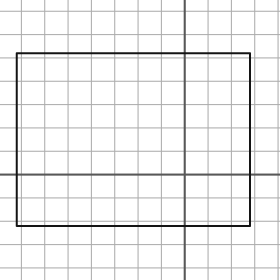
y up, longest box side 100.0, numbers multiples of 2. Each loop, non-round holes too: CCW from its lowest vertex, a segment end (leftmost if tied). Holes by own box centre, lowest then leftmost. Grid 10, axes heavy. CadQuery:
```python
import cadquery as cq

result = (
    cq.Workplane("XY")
    .moveTo(-72.0, -22.0)
    .lineTo(28.0, -22.0)
    .lineTo(28.0, 52.0)
    .lineTo(-72.0, 52.0)
    .close()
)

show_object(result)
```